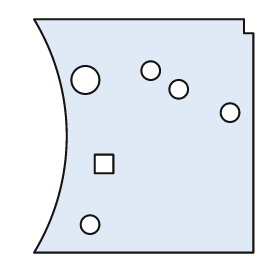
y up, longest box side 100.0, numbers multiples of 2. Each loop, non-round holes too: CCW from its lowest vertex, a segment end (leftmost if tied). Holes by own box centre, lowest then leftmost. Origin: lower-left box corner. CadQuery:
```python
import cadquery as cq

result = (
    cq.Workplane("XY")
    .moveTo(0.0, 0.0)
    .lineTo(94.0, 0.0)
    .lineTo(94.0, 94.0)
    .lineTo(90.0, 94.0)
    .lineTo(90.0, 100.0)
    .lineTo(0.0, 100.0)
    .threePointArc((14.0, 50.0), (0.0, 0.0))
    .close()
    .moveTo(24.0, 12.0)
    .circle(4.0)
    .moveTo(26.0, 34.0)
    .lineTo(34.0, 34.0)
    .lineTo(34.0, 42.0)
    .lineTo(26.0, 42.0)
    .close()
    .moveTo(84.0, 60.0)
    .circle(4.0)
    .moveTo(62.0, 70.0)
    .circle(4.0)
    .moveTo(22.0, 74.0)
    .circle(6.0)
    .moveTo(50.0, 78.0)
    .circle(4.0)
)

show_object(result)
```